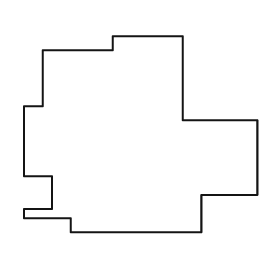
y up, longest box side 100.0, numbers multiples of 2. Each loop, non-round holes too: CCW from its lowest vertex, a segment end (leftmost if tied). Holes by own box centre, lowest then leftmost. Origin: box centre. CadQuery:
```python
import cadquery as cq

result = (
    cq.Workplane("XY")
    .moveTo(-30.0, -42.0)
    .lineTo(26.0, -42.0)
    .lineTo(26.0, -26.0)
    .lineTo(50.0, -26.0)
    .lineTo(50.0, 6.0)
    .lineTo(18.0, 6.0)
    .lineTo(18.0, 42.0)
    .lineTo(-12.0, 42.0)
    .lineTo(-12.0, 36.0)
    .lineTo(-42.0, 36.0)
    .lineTo(-42.0, 12.0)
    .lineTo(-50.0, 12.0)
    .lineTo(-50.0, -18.0)
    .lineTo(-38.0, -18.0)
    .lineTo(-38.0, -32.0)
    .lineTo(-50.0, -32.0)
    .lineTo(-50.0, -36.0)
    .lineTo(-30.0, -36.0)
    .close()
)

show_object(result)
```